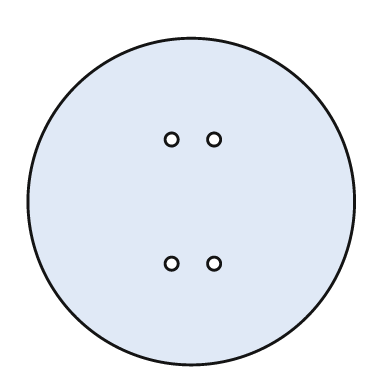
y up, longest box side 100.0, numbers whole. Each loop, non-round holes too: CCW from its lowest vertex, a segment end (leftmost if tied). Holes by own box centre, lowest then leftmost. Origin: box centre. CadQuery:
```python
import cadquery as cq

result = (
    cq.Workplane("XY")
    .moveTo(0.0, 0.0)
    .circle(50.0)
    .moveTo(-6.0, -19.0)
    .circle(2.0)
    .moveTo(7.0, -19.0)
    .circle(2.0)
    .moveTo(-6.0, 19.0)
    .circle(2.0)
    .moveTo(7.0, 19.0)
    .circle(2.0)
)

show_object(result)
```